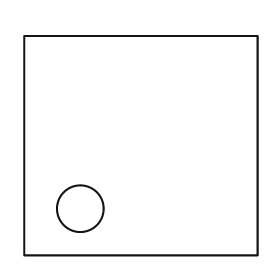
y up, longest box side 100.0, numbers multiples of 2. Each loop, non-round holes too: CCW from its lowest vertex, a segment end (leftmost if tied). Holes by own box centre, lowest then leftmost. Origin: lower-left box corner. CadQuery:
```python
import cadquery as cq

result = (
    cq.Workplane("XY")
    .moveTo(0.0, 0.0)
    .lineTo(100.0, 0.0)
    .lineTo(100.0, 94.0)
    .lineTo(0.0, 94.0)
    .close()
    .moveTo(24.0, 20.0)
    .circle(10.0)
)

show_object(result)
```